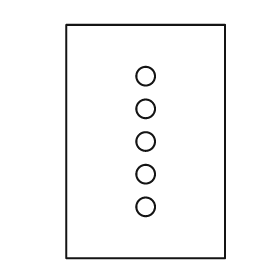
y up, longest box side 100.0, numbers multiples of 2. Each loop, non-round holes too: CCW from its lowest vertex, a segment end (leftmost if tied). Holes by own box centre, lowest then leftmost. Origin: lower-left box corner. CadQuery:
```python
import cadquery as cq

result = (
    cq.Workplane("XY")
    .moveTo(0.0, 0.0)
    .lineTo(68.0, 0.0)
    .lineTo(68.0, 100.0)
    .lineTo(0.0, 100.0)
    .close()
    .moveTo(34.0, 22.0)
    .circle(4.0)
    .moveTo(34.0, 36.0)
    .circle(4.0)
    .moveTo(34.0, 50.0)
    .circle(4.0)
    .moveTo(34.0, 64.0)
    .circle(4.0)
    .moveTo(34.0, 78.0)
    .circle(4.0)
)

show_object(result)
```